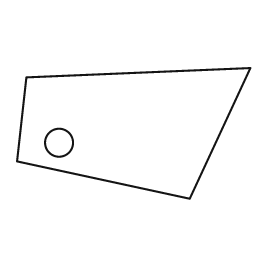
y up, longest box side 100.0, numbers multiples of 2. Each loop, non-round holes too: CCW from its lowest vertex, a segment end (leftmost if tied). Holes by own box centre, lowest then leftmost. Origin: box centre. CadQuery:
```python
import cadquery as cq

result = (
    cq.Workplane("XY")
    .moveTo(24.0, -28.0)
    .lineTo(50.0, 28.0)
    .lineTo(-46.0, 24.0)
    .lineTo(-50.0, -12.0)
    .close()
    .moveTo(-32.0, -4.0)
    .circle(6.0)
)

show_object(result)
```